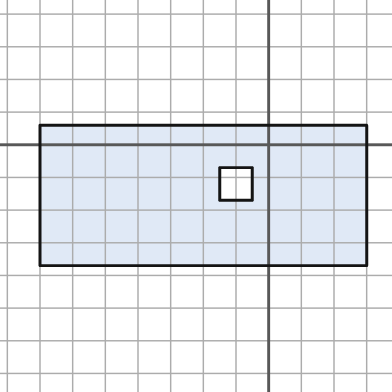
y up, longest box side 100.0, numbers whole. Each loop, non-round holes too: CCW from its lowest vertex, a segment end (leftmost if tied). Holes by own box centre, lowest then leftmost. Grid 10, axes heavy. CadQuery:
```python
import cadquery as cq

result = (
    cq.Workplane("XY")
    .moveTo(-70.0, -37.0)
    .lineTo(30.0, -37.0)
    .lineTo(30.0, 6.0)
    .lineTo(-70.0, 6.0)
    .close()
    .moveTo(-15.0, -17.0)
    .lineTo(-5.0, -17.0)
    .lineTo(-5.0, -7.0)
    .lineTo(-15.0, -7.0)
    .close()
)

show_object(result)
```